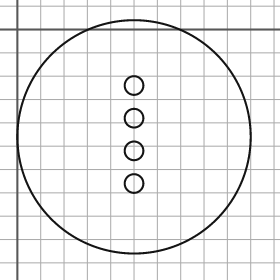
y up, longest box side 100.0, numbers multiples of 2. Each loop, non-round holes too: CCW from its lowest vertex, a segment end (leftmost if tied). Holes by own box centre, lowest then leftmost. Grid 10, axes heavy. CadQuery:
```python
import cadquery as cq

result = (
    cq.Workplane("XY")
    .moveTo(50.0, -46.0)
    .circle(50.0)
    .moveTo(50.0, -66.0)
    .circle(4.0)
    .moveTo(50.0, -52.0)
    .circle(4.0)
    .moveTo(50.0, -38.0)
    .circle(4.0)
    .moveTo(50.0, -24.0)
    .circle(4.0)
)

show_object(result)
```